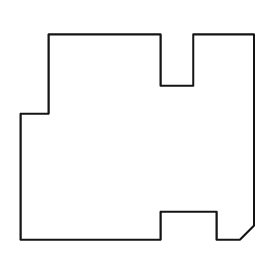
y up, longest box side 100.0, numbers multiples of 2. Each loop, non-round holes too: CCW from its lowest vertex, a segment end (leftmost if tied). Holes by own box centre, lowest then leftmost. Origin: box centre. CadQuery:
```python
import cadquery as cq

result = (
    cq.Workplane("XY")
    .moveTo(-50.0, -44.0)
    .lineTo(10.0, -44.0)
    .lineTo(10.0, -32.0)
    .lineTo(34.0, -32.0)
    .lineTo(34.0, -44.0)
    .lineTo(44.0, -44.0)
    .lineTo(50.0, -38.0)
    .lineTo(50.0, 44.0)
    .lineTo(24.0, 44.0)
    .lineTo(24.0, 22.0)
    .lineTo(10.0, 22.0)
    .lineTo(10.0, 44.0)
    .lineTo(-38.0, 44.0)
    .lineTo(-38.0, 10.0)
    .lineTo(-50.0, 10.0)
    .close()
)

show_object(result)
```